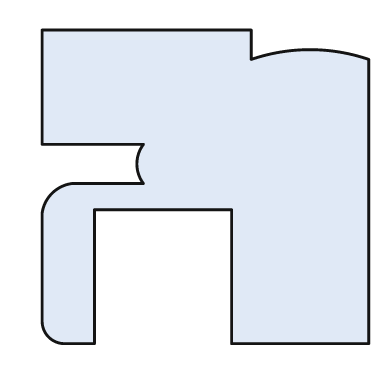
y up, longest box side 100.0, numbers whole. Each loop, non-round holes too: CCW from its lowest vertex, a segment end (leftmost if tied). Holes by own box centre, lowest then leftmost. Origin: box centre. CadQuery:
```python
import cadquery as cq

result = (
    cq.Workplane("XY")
    .moveTo(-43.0, -48.0)
    .lineTo(-34.0, -48.0)
    .lineTo(-34.0, -7.0)
    .lineTo(8.0, -7.0)
    .lineTo(8.0, -48.0)
    .lineTo(50.0, -48.0)
    .lineTo(50.0, 39.0)
    .threePointArc((32.0, 42.0), (14.0, 39.0))
    .lineTo(14.0, 48.0)
    .lineTo(-50.0, 48.0)
    .lineTo(-50.0, 13.0)
    .lineTo(-19.0, 13.0)
    .threePointArc((-21.0, 7.0), (-19.0, 1.0))
    .lineTo(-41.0, 1.0)
    .threePointArc((-47.0, -2.0), (-50.0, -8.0))
    .lineTo(-50.0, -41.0)
    .threePointArc((-48.0, -46.0), (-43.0, -48.0))
    .close()
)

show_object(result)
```